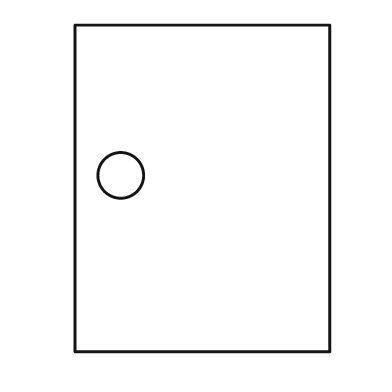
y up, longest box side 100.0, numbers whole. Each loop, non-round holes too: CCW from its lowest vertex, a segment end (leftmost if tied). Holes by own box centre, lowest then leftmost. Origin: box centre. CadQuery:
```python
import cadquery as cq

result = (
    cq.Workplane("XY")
    .moveTo(-39.0, -50.0)
    .lineTo(39.0, -50.0)
    .lineTo(39.0, 50.0)
    .lineTo(-39.0, 50.0)
    .close()
    .moveTo(-25.0, 4.0)
    .circle(7.0)
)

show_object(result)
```